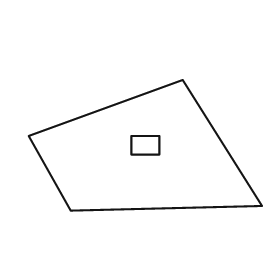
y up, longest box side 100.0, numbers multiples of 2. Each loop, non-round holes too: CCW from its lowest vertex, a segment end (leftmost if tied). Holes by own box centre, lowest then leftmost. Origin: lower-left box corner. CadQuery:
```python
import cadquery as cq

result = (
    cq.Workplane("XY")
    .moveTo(18.0, 0.0)
    .lineTo(100.0, 2.0)
    .lineTo(66.0, 56.0)
    .lineTo(0.0, 32.0)
    .close()
    .moveTo(44.0, 24.0)
    .lineTo(56.0, 24.0)
    .lineTo(56.0, 32.0)
    .lineTo(44.0, 32.0)
    .close()
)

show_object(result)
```